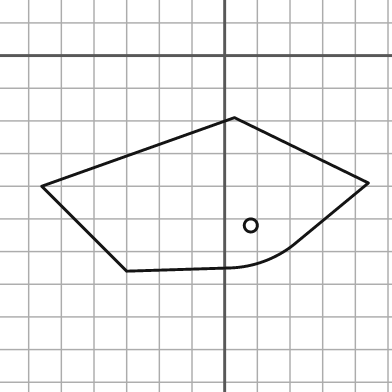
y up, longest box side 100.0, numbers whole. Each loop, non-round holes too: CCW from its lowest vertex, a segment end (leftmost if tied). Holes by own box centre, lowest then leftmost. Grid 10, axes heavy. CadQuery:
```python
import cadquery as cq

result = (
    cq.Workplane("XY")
    .moveTo(-30.0, -66.0)
    .lineTo(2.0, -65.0)
    .threePointArc((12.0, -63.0), (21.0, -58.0))
    .lineTo(44.0, -39.0)
    .lineTo(3.0, -19.0)
    .lineTo(-56.0, -40.0)
    .close()
    .moveTo(8.0, -52.0)
    .circle(2.0)
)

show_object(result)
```